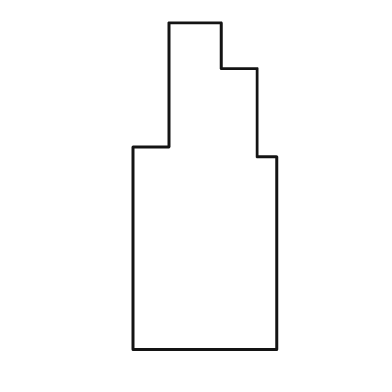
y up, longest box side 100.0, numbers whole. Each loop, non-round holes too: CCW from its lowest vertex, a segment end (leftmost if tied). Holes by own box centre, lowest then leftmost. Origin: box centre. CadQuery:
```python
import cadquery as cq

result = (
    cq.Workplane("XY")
    .moveTo(-22.0, -50.0)
    .lineTo(22.0, -50.0)
    .lineTo(22.0, 9.0)
    .lineTo(16.0, 9.0)
    .lineTo(16.0, 36.0)
    .lineTo(5.0, 36.0)
    .lineTo(5.0, 50.0)
    .lineTo(-11.0, 50.0)
    .lineTo(-11.0, 12.0)
    .lineTo(-22.0, 12.0)
    .close()
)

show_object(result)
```